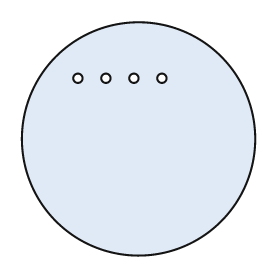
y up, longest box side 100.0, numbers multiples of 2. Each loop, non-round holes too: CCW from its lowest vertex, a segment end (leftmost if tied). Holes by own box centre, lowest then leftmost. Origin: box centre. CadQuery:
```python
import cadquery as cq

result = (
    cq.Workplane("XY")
    .moveTo(0.0, 0.0)
    .circle(50.0)
    .moveTo(-26.0, 26.0)
    .circle(2.0)
    .moveTo(-14.0, 26.0)
    .circle(2.0)
    .moveTo(-2.0, 26.0)
    .circle(2.0)
    .moveTo(10.0, 26.0)
    .circle(2.0)
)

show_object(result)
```